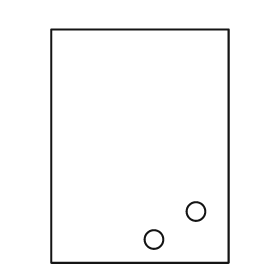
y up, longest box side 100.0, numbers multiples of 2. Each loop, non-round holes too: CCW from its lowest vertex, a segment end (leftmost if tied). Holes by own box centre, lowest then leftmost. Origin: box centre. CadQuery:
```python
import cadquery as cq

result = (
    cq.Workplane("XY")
    .moveTo(-38.0, -50.0)
    .lineTo(38.0, -50.0)
    .lineTo(38.0, 50.0)
    .lineTo(-38.0, 50.0)
    .close()
    .moveTo(6.0, -40.0)
    .circle(4.0)
    .moveTo(24.0, -28.0)
    .circle(4.0)
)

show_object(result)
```